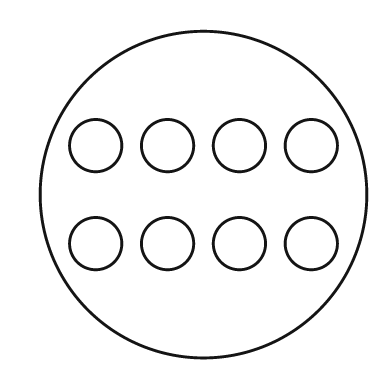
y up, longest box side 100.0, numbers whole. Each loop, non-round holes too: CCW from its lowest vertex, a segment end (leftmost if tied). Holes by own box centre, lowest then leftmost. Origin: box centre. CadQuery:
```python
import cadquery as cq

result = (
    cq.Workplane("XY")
    .moveTo(0.0, 0.0)
    .circle(50.0)
    .moveTo(-33.0, -15.0)
    .circle(8.0)
    .moveTo(-11.0, -15.0)
    .circle(8.0)
    .moveTo(11.0, -15.0)
    .circle(8.0)
    .moveTo(33.0, -15.0)
    .circle(8.0)
    .moveTo(-33.0, 15.0)
    .circle(8.0)
    .moveTo(-11.0, 15.0)
    .circle(8.0)
    .moveTo(11.0, 15.0)
    .circle(8.0)
    .moveTo(33.0, 15.0)
    .circle(8.0)
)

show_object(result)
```